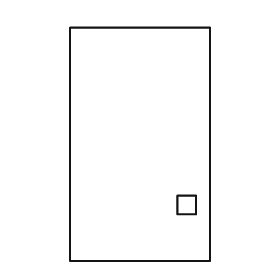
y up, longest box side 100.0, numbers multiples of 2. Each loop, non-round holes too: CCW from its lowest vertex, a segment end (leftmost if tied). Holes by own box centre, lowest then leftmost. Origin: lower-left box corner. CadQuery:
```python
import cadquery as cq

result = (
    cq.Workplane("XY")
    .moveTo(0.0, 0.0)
    .lineTo(60.0, 0.0)
    .lineTo(60.0, 100.0)
    .lineTo(0.0, 100.0)
    .close()
    .moveTo(46.0, 20.0)
    .lineTo(54.0, 20.0)
    .lineTo(54.0, 28.0)
    .lineTo(46.0, 28.0)
    .close()
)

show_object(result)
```